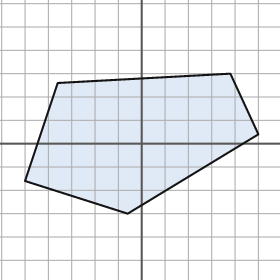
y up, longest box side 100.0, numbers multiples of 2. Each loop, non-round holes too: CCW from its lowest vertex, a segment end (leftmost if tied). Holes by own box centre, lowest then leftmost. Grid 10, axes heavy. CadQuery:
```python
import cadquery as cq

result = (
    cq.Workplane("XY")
    .moveTo(-6.0, -30.0)
    .lineTo(50.0, 4.0)
    .lineTo(38.0, 30.0)
    .lineTo(-36.0, 26.0)
    .lineTo(-50.0, -16.0)
    .close()
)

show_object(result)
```